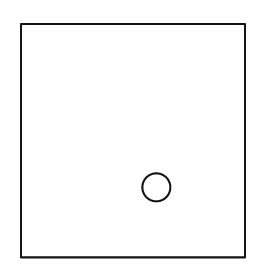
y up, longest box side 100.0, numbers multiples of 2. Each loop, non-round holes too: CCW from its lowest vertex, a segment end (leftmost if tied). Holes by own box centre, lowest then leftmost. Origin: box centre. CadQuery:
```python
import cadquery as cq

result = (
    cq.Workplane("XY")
    .moveTo(-48.0, -50.0)
    .lineTo(48.0, -50.0)
    .lineTo(48.0, 50.0)
    .lineTo(-48.0, 50.0)
    .close()
    .moveTo(10.0, -20.0)
    .circle(6.0)
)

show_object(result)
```